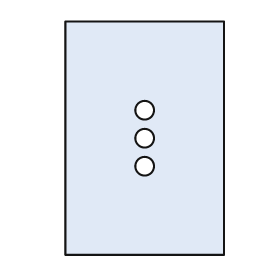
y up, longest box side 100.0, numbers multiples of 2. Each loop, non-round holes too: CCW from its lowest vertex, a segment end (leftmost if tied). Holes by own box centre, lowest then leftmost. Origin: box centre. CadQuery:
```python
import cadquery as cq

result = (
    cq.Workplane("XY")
    .moveTo(-34.0, -50.0)
    .lineTo(34.0, -50.0)
    .lineTo(34.0, 50.0)
    .lineTo(-34.0, 50.0)
    .close()
    .moveTo(0.0, -12.0)
    .circle(4.0)
    .moveTo(0.0, 0.0)
    .circle(4.0)
    .moveTo(0.0, 12.0)
    .circle(4.0)
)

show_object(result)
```